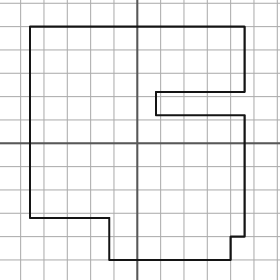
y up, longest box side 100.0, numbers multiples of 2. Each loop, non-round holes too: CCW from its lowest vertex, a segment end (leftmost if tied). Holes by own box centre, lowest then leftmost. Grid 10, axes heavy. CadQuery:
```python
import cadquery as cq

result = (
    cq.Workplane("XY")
    .moveTo(-12.0, -50.0)
    .lineTo(40.0, -50.0)
    .lineTo(40.0, -40.0)
    .lineTo(46.0, -40.0)
    .lineTo(46.0, 12.0)
    .lineTo(8.0, 12.0)
    .lineTo(8.0, 22.0)
    .lineTo(46.0, 22.0)
    .lineTo(46.0, 50.0)
    .lineTo(-46.0, 50.0)
    .lineTo(-46.0, -32.0)
    .lineTo(-12.0, -32.0)
    .close()
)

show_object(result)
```